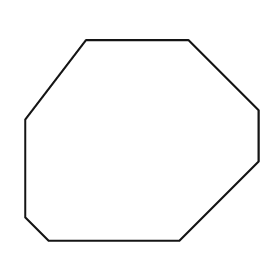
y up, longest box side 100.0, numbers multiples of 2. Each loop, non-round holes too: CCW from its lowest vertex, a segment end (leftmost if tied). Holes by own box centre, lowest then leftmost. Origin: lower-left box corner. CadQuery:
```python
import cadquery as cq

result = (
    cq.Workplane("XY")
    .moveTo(10.0, 0.0)
    .lineTo(66.0, 0.0)
    .lineTo(100.0, 34.0)
    .lineTo(100.0, 56.0)
    .lineTo(70.0, 86.0)
    .lineTo(26.0, 86.0)
    .lineTo(0.0, 52.0)
    .lineTo(0.0, 10.0)
    .close()
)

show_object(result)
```